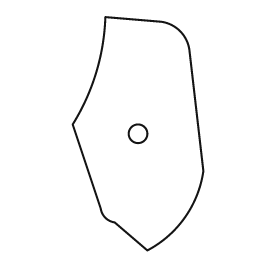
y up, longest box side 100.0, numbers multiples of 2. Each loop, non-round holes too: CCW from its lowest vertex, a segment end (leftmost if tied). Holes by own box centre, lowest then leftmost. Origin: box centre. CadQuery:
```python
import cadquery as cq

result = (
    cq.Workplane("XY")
    .moveTo(4.0, -50.0)
    .threePointArc((20.0, -36.0), (28.0, -16.0))
    .lineTo(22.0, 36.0)
    .threePointArc((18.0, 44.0), (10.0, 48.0))
    .lineTo(-14.0, 50.0)
    .threePointArc((-18.0, 26.0), (-28.0, 4.0))
    .lineTo(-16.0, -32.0)
    .threePointArc((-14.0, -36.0), (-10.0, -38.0))
    .close()
    .moveTo(0.0, 0.0)
    .circle(4.0)
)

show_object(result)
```